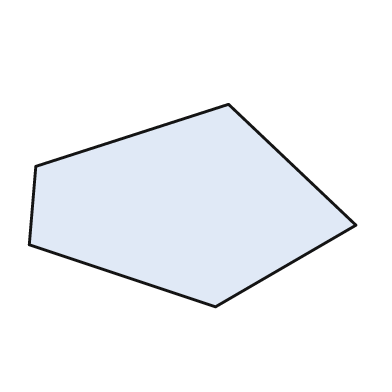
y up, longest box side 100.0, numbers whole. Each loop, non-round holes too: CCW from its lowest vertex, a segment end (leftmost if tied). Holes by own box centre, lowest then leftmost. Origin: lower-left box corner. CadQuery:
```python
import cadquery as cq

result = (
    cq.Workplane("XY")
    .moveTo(57.0, 0.0)
    .lineTo(100.0, 25.0)
    .lineTo(61.0, 62.0)
    .lineTo(2.0, 43.0)
    .lineTo(0.0, 19.0)
    .close()
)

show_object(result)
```